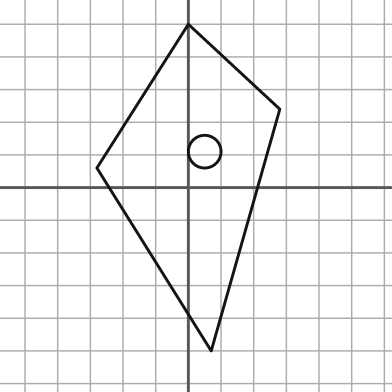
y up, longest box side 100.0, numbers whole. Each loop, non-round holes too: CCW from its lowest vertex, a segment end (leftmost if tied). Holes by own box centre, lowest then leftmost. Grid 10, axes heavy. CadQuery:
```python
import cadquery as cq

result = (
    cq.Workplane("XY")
    .moveTo(7.0, -50.0)
    .lineTo(28.0, 24.0)
    .lineTo(0.0, 50.0)
    .lineTo(-28.0, 6.0)
    .close()
    .moveTo(5.0, 11.0)
    .circle(5.0)
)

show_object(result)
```